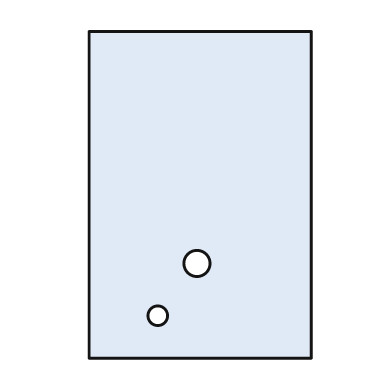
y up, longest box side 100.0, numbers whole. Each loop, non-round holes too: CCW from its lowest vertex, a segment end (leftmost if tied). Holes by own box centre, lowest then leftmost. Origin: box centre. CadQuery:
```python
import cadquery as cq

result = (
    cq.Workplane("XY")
    .moveTo(-34.0, -50.0)
    .lineTo(34.0, -50.0)
    .lineTo(34.0, 50.0)
    .lineTo(-34.0, 50.0)
    .close()
    .moveTo(-13.0, -37.0)
    .circle(3.0)
    .moveTo(-1.0, -21.0)
    .circle(4.0)
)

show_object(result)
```